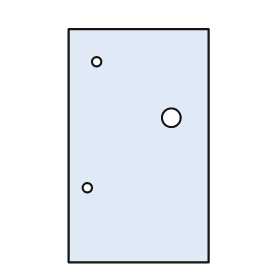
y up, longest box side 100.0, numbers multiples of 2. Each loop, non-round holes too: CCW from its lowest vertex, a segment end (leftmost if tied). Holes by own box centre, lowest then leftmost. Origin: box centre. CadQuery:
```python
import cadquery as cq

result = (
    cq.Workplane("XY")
    .moveTo(-30.0, -50.0)
    .lineTo(30.0, -50.0)
    .lineTo(30.0, 50.0)
    .lineTo(-30.0, 50.0)
    .close()
    .moveTo(-22.0, -18.0)
    .circle(2.0)
    .moveTo(14.0, 12.0)
    .circle(4.0)
    .moveTo(-18.0, 36.0)
    .circle(2.0)
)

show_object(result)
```